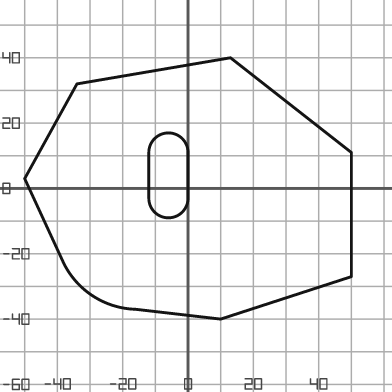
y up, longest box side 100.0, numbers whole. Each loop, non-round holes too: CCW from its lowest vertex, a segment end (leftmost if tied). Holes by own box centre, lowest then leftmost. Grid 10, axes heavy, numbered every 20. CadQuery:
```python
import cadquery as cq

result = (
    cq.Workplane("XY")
    .moveTo(10.0, -40.0)
    .lineTo(50.0, -27.0)
    .lineTo(50.0, 11.0)
    .lineTo(13.0, 40.0)
    .lineTo(-34.0, 32.0)
    .lineTo(-50.0, 3.0)
    .lineTo(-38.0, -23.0)
    .threePointArc((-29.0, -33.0), (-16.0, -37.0))
    .close()
    .moveTo(-12.0, -3.0)
    .threePointArc((-6.0, -9.0), (0.0, -3.0))
    .lineTo(0.0, 11.0)
    .threePointArc((-6.0, 17.0), (-12.0, 11.0))
    .close()
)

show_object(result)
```